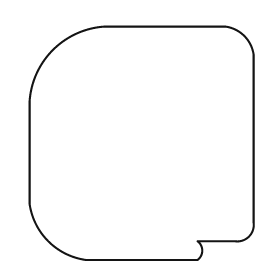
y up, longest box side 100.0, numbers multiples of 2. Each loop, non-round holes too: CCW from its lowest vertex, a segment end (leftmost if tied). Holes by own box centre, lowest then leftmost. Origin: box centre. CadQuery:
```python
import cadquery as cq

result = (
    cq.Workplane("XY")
    .moveTo(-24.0, -50.0)
    .lineTo(24.0, -50.0)
    .threePointArc((26.0, -46.0), (24.0, -42.0))
    .lineTo(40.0, -42.0)
    .threePointArc((46.0, -40.0), (48.0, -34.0))
    .lineTo(48.0, 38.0)
    .threePointArc((44.0, 46.0), (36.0, 50.0))
    .lineTo(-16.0, 50.0)
    .threePointArc((-38.0, 40.0), (-48.0, 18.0))
    .lineTo(-48.0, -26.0)
    .threePointArc((-40.0, -42.0), (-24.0, -50.0))
    .close()
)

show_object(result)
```